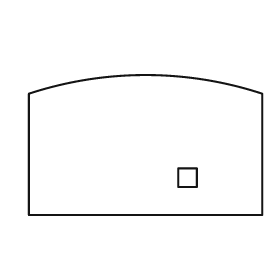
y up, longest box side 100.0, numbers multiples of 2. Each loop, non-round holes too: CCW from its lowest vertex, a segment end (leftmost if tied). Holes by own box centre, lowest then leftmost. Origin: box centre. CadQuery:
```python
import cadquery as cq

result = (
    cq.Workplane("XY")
    .moveTo(-50.0, -30.0)
    .lineTo(50.0, -30.0)
    .lineTo(50.0, 22.0)
    .threePointArc((0.0, 30.0), (-50.0, 22.0))
    .close()
    .moveTo(14.0, -18.0)
    .lineTo(22.0, -18.0)
    .lineTo(22.0, -10.0)
    .lineTo(14.0, -10.0)
    .close()
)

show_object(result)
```